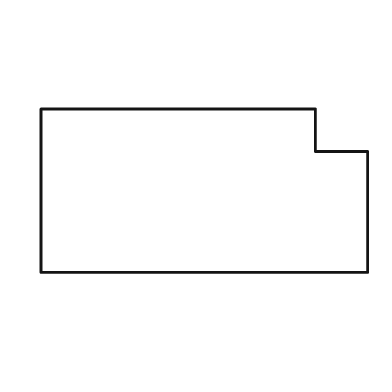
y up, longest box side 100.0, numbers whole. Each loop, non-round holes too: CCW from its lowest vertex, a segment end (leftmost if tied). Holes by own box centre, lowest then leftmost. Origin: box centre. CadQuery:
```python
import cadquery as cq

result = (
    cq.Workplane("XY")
    .moveTo(-50.0, -25.0)
    .lineTo(50.0, -25.0)
    .lineTo(50.0, 12.0)
    .lineTo(34.0, 12.0)
    .lineTo(34.0, 25.0)
    .lineTo(-50.0, 25.0)
    .close()
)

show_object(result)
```